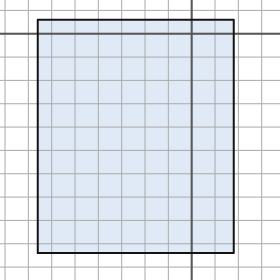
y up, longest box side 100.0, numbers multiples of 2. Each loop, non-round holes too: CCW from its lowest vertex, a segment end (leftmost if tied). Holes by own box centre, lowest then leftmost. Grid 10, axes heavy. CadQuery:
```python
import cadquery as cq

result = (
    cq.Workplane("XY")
    .moveTo(-66.0, -94.0)
    .lineTo(18.0, -94.0)
    .lineTo(18.0, 6.0)
    .lineTo(-66.0, 6.0)
    .close()
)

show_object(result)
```